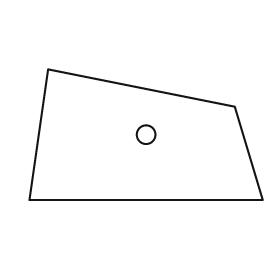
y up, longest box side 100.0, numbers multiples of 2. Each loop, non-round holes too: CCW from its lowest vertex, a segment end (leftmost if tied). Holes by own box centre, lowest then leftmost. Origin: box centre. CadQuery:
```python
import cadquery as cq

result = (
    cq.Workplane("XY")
    .moveTo(-50.0, -28.0)
    .lineTo(50.0, -28.0)
    .lineTo(38.0, 12.0)
    .lineTo(-42.0, 28.0)
    .close()
    .moveTo(0.0, 0.0)
    .circle(4.0)
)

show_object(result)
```